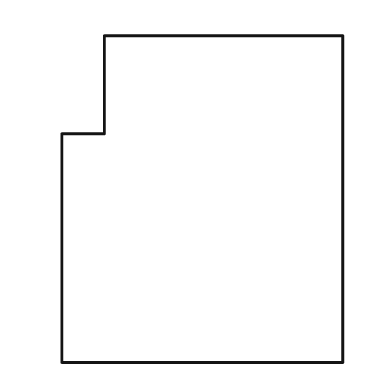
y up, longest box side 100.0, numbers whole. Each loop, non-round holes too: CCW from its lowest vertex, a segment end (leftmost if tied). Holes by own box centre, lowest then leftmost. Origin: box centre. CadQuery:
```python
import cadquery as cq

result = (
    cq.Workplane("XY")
    .moveTo(-43.0, -50.0)
    .lineTo(43.0, -50.0)
    .lineTo(43.0, 50.0)
    .lineTo(-30.0, 50.0)
    .lineTo(-30.0, 20.0)
    .lineTo(-43.0, 20.0)
    .close()
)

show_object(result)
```